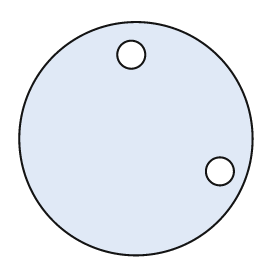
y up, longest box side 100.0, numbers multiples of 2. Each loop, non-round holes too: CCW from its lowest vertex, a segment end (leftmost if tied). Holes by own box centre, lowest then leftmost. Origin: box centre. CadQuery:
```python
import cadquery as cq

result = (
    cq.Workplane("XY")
    .moveTo(0.0, 0.0)
    .circle(50.0)
    .moveTo(36.0, -14.0)
    .circle(6.0)
    .moveTo(-2.0, 36.0)
    .circle(6.0)
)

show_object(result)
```